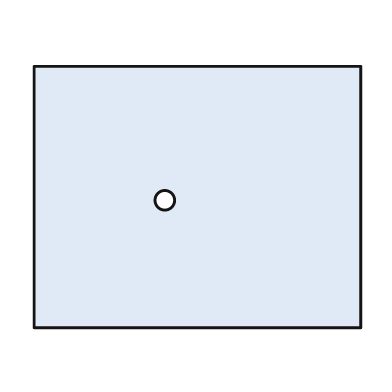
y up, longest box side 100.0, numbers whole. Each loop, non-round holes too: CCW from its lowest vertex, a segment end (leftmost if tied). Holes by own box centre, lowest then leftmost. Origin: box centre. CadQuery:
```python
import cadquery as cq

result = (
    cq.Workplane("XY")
    .moveTo(-50.0, -40.0)
    .lineTo(50.0, -40.0)
    .lineTo(50.0, 40.0)
    .lineTo(-50.0, 40.0)
    .close()
    .moveTo(-10.0, -1.0)
    .circle(3.0)
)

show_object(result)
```